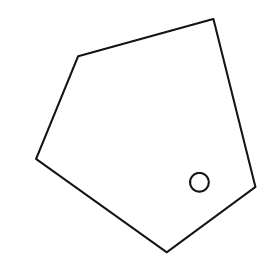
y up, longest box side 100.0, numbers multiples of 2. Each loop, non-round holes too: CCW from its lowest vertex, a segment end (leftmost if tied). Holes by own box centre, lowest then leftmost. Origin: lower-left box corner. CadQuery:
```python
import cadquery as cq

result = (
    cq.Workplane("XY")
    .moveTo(56.0, 0.0)
    .lineTo(94.0, 28.0)
    .lineTo(76.0, 100.0)
    .lineTo(18.0, 84.0)
    .lineTo(0.0, 40.0)
    .close()
    .moveTo(70.0, 30.0)
    .circle(4.0)
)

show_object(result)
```